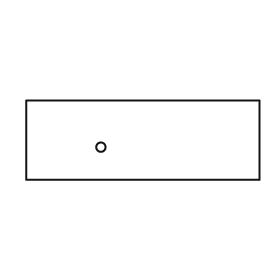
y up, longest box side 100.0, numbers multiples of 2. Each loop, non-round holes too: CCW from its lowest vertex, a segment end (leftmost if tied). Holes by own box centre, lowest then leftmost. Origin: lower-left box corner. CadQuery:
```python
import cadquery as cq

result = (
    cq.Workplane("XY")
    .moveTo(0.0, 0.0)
    .lineTo(100.0, 0.0)
    .lineTo(100.0, 34.0)
    .lineTo(0.0, 34.0)
    .close()
    .moveTo(32.0, 14.0)
    .circle(2.0)
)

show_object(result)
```